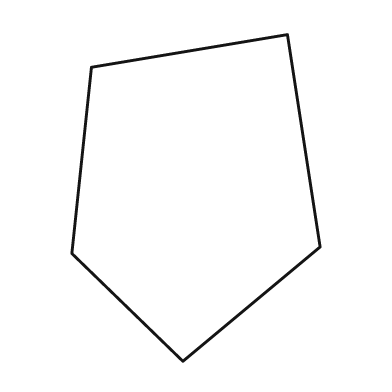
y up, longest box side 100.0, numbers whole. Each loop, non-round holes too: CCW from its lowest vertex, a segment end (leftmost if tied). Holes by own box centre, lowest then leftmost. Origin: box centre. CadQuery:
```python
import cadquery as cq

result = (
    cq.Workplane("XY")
    .moveTo(-4.0, -50.0)
    .lineTo(38.0, -15.0)
    .lineTo(28.0, 50.0)
    .lineTo(-32.0, 40.0)
    .lineTo(-38.0, -17.0)
    .close()
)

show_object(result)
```